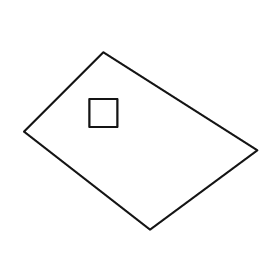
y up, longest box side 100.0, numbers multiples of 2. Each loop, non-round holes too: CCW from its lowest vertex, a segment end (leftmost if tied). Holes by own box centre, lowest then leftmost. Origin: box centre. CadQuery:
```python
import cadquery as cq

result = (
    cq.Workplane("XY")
    .moveTo(4.0, -38.0)
    .lineTo(50.0, -4.0)
    .lineTo(-16.0, 38.0)
    .lineTo(-50.0, 4.0)
    .close()
    .moveTo(-22.0, 6.0)
    .lineTo(-10.0, 6.0)
    .lineTo(-10.0, 18.0)
    .lineTo(-22.0, 18.0)
    .close()
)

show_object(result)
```